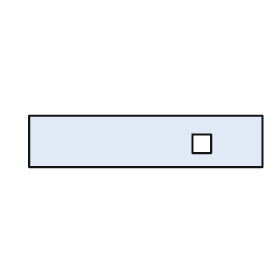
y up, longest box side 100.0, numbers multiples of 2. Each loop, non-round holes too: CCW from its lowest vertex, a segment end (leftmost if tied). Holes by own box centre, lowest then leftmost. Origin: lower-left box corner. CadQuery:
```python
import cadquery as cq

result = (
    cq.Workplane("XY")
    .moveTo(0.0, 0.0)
    .lineTo(100.0, 0.0)
    .lineTo(100.0, 22.0)
    .lineTo(0.0, 22.0)
    .close()
    .moveTo(70.0, 6.0)
    .lineTo(78.0, 6.0)
    .lineTo(78.0, 14.0)
    .lineTo(70.0, 14.0)
    .close()
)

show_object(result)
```